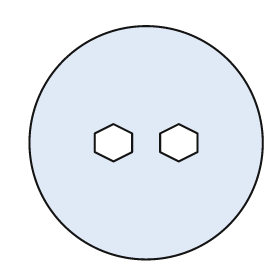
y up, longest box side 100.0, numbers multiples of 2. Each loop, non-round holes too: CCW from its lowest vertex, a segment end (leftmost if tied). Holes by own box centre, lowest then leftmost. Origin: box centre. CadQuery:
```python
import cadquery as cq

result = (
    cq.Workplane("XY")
    .moveTo(0.0, 0.0)
    .circle(50.0)
    .moveTo(-14.0, -8.0)
    .lineTo(-6.0, -4.0)
    .lineTo(-6.0, 4.0)
    .lineTo(-14.0, 8.0)
    .lineTo(-22.0, 4.0)
    .lineTo(-22.0, -4.0)
    .close()
    .moveTo(14.0, -8.0)
    .lineTo(22.0, -4.0)
    .lineTo(22.0, 4.0)
    .lineTo(14.0, 8.0)
    .lineTo(6.0, 4.0)
    .lineTo(6.0, -4.0)
    .close()
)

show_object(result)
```